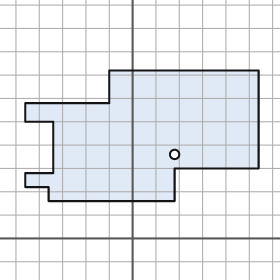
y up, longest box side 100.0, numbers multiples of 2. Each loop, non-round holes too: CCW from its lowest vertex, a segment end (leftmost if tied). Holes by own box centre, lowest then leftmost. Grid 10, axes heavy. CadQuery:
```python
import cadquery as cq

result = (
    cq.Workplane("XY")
    .moveTo(-36.0, 16.0)
    .lineTo(18.0, 16.0)
    .lineTo(18.0, 30.0)
    .lineTo(54.0, 30.0)
    .lineTo(54.0, 72.0)
    .lineTo(-10.0, 72.0)
    .lineTo(-10.0, 58.0)
    .lineTo(-46.0, 58.0)
    .lineTo(-46.0, 50.0)
    .lineTo(-34.0, 50.0)
    .lineTo(-34.0, 28.0)
    .lineTo(-46.0, 28.0)
    .lineTo(-46.0, 22.0)
    .lineTo(-36.0, 22.0)
    .close()
    .moveTo(18.0, 36.0)
    .circle(2.0)
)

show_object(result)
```